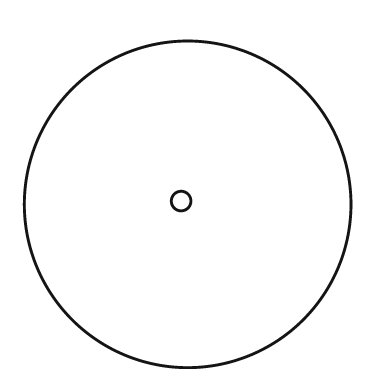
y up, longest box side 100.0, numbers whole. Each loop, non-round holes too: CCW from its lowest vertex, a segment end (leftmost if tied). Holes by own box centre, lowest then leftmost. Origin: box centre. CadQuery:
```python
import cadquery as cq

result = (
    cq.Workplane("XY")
    .moveTo(0.0, 0.0)
    .circle(50.0)
    .moveTo(-2.0, 1.0)
    .circle(3.0)
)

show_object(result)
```